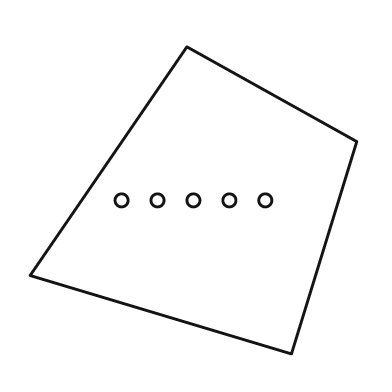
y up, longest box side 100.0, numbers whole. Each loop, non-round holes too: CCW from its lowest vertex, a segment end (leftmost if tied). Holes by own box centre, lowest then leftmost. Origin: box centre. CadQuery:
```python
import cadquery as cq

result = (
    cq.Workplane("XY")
    .moveTo(30.0, -47.0)
    .lineTo(50.0, 18.0)
    .lineTo(-2.0, 47.0)
    .lineTo(-50.0, -23.0)
    .close()
    .moveTo(-22.0, 0.0)
    .circle(2.0)
    .moveTo(-11.0, 0.0)
    .circle(2.0)
    .moveTo(0.0, 0.0)
    .circle(2.0)
    .moveTo(11.0, 0.0)
    .circle(2.0)
    .moveTo(22.0, 0.0)
    .circle(2.0)
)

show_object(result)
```